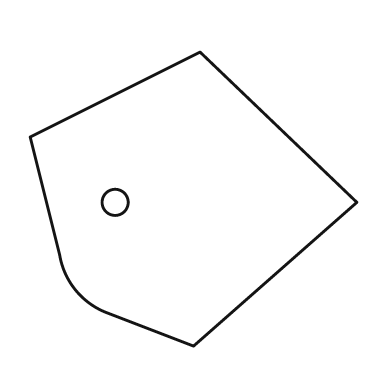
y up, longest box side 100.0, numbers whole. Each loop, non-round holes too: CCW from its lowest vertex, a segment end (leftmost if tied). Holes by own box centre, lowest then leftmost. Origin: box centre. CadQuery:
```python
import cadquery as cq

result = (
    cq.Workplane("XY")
    .moveTo(0.0, -45.0)
    .lineTo(50.0, -1.0)
    .lineTo(2.0, 45.0)
    .lineTo(-50.0, 19.0)
    .lineTo(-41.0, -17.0)
    .threePointArc((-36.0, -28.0), (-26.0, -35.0))
    .close()
    .moveTo(-24.0, -1.0)
    .circle(4.0)
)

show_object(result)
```